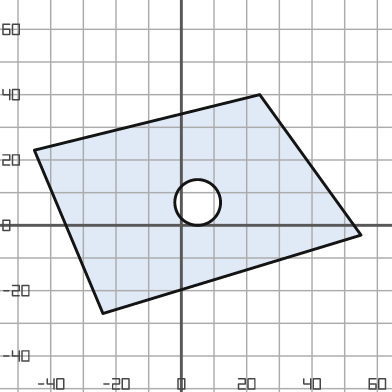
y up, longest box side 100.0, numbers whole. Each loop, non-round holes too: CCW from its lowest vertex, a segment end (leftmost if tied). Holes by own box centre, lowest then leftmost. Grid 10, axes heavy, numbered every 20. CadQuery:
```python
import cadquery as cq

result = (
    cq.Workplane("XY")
    .moveTo(-24.0, -27.0)
    .lineTo(55.0, -3.0)
    .lineTo(24.0, 40.0)
    .lineTo(-45.0, 23.0)
    .close()
    .moveTo(5.0, 7.0)
    .circle(7.0)
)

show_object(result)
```